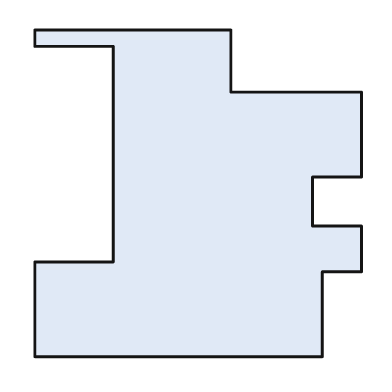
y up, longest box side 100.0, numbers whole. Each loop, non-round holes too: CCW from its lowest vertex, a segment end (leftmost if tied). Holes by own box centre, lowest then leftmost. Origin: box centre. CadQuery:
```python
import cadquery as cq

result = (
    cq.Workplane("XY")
    .moveTo(-50.0, -50.0)
    .lineTo(38.0, -50.0)
    .lineTo(38.0, -24.0)
    .lineTo(50.0, -24.0)
    .lineTo(50.0, -10.0)
    .lineTo(35.0, -10.0)
    .lineTo(35.0, 5.0)
    .lineTo(50.0, 5.0)
    .lineTo(50.0, 31.0)
    .lineTo(10.0, 31.0)
    .lineTo(10.0, 50.0)
    .lineTo(-50.0, 50.0)
    .lineTo(-50.0, 45.0)
    .lineTo(-26.0, 45.0)
    .lineTo(-26.0, -21.0)
    .lineTo(-50.0, -21.0)
    .close()
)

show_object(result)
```